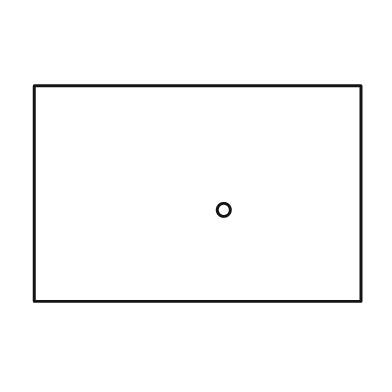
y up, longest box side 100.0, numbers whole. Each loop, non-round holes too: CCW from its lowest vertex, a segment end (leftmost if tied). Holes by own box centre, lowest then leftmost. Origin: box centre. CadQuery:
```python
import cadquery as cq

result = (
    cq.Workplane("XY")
    .moveTo(-50.0, -33.0)
    .lineTo(50.0, -33.0)
    .lineTo(50.0, 33.0)
    .lineTo(-50.0, 33.0)
    .close()
    .moveTo(8.0, -5.0)
    .circle(2.0)
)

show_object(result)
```